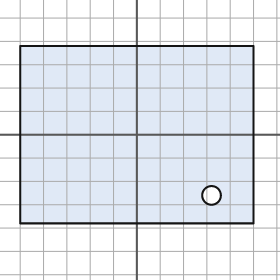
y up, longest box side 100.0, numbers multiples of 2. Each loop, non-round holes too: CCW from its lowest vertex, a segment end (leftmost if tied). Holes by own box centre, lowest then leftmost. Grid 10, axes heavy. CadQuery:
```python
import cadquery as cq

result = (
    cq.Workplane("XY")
    .moveTo(-50.0, -38.0)
    .lineTo(50.0, -38.0)
    .lineTo(50.0, 38.0)
    .lineTo(-50.0, 38.0)
    .close()
    .moveTo(32.0, -26.0)
    .circle(4.0)
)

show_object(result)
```